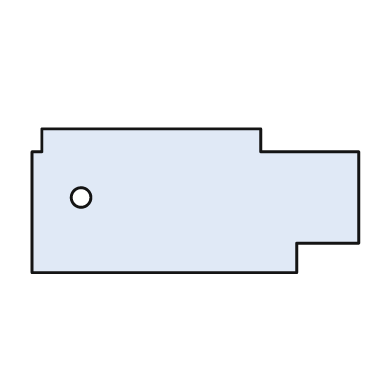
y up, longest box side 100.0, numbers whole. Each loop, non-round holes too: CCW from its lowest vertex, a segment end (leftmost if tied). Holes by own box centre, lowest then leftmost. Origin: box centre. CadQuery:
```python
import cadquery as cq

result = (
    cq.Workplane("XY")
    .moveTo(-50.0, -22.0)
    .lineTo(31.0, -22.0)
    .lineTo(31.0, -13.0)
    .lineTo(50.0, -13.0)
    .lineTo(50.0, 15.0)
    .lineTo(20.0, 15.0)
    .lineTo(20.0, 22.0)
    .lineTo(-47.0, 22.0)
    .lineTo(-47.0, 15.0)
    .lineTo(-50.0, 15.0)
    .close()
    .moveTo(-35.0, 1.0)
    .circle(3.0)
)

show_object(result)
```